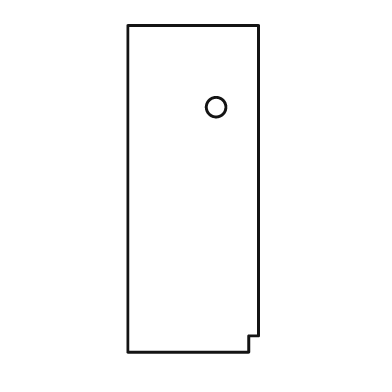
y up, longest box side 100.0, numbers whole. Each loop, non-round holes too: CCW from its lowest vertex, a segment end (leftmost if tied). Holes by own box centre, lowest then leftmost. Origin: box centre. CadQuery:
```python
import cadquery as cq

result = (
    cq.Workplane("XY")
    .moveTo(-20.0, -50.0)
    .lineTo(17.0, -50.0)
    .lineTo(17.0, -45.0)
    .lineTo(20.0, -45.0)
    .lineTo(20.0, 50.0)
    .lineTo(-20.0, 50.0)
    .close()
    .moveTo(7.0, 25.0)
    .circle(3.0)
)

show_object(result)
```